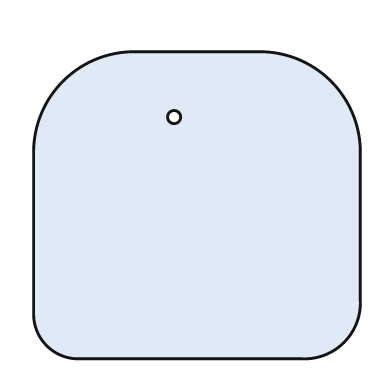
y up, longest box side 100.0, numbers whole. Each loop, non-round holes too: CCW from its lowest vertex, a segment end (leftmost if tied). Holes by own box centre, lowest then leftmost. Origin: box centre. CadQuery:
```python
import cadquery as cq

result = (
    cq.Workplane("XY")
    .moveTo(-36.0, -47.0)
    .lineTo(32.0, -47.0)
    .threePointArc((45.0, -42.0), (50.0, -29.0))
    .lineTo(50.0, 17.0)
    .threePointArc((41.0, 38.0), (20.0, 47.0))
    .lineTo(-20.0, 47.0)
    .threePointArc((-41.0, 38.0), (-50.0, 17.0))
    .lineTo(-50.0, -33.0)
    .threePointArc((-46.0, -43.0), (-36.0, -47.0))
    .close()
    .moveTo(-7.0, 27.0)
    .circle(2.0)
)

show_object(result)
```